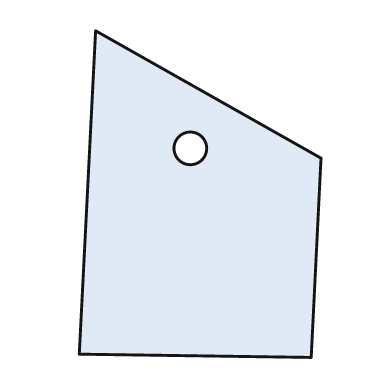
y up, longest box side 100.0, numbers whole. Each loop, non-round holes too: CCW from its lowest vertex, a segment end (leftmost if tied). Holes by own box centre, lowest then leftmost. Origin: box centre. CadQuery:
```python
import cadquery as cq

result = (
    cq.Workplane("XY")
    .moveTo(34.0, -50.0)
    .lineTo(37.0, 11.0)
    .lineTo(-32.0, 50.0)
    .lineTo(-37.0, -49.0)
    .close()
    .moveTo(-3.0, 14.0)
    .circle(5.0)
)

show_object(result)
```